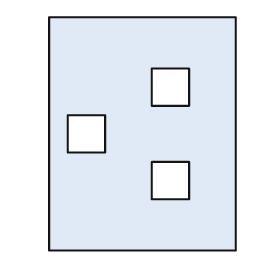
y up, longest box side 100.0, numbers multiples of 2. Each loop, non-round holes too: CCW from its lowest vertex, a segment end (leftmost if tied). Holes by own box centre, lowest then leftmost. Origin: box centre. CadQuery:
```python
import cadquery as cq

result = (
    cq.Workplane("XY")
    .moveTo(-40.0, -50.0)
    .lineTo(40.0, -50.0)
    .lineTo(40.0, 50.0)
    .lineTo(-40.0, 50.0)
    .close()
    .moveTo(4.0, -28.0)
    .lineTo(20.0, -28.0)
    .lineTo(20.0, -12.0)
    .lineTo(4.0, -12.0)
    .close()
    .moveTo(-32.0, -8.0)
    .lineTo(-16.0, -8.0)
    .lineTo(-16.0, 8.0)
    .lineTo(-32.0, 8.0)
    .close()
    .moveTo(4.0, 12.0)
    .lineTo(20.0, 12.0)
    .lineTo(20.0, 28.0)
    .lineTo(4.0, 28.0)
    .close()
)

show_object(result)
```